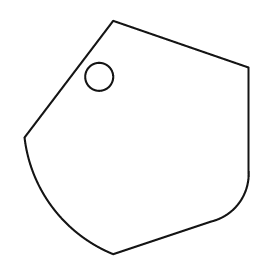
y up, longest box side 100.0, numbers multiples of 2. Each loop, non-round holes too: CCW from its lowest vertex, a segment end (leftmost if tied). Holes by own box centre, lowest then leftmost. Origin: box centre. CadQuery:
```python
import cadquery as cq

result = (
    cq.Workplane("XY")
    .moveTo(-10.0, -50.0)
    .lineTo(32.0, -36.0)
    .threePointArc((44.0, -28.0), (48.0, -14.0))
    .lineTo(48.0, 30.0)
    .lineTo(-10.0, 50.0)
    .lineTo(-48.0, 0.0)
    .threePointArc((-36.0, -30.0), (-10.0, -50.0))
    .close()
    .moveTo(-16.0, 26.0)
    .circle(6.0)
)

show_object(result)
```